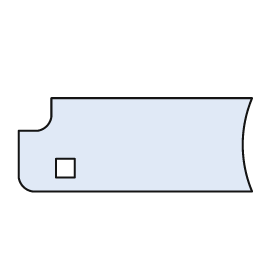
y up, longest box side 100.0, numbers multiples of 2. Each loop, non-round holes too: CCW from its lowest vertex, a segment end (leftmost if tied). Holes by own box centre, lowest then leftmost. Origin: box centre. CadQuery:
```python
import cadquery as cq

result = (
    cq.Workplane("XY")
    .moveTo(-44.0, -20.0)
    .lineTo(50.0, -20.0)
    .threePointArc((46.0, 0.0), (50.0, 20.0))
    .lineTo(-36.0, 20.0)
    .lineTo(-36.0, 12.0)
    .threePointArc((-38.0, 8.0), (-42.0, 6.0))
    .lineTo(-50.0, 6.0)
    .lineTo(-50.0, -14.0)
    .threePointArc((-48.0, -18.0), (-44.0, -20.0))
    .close()
    .moveTo(-34.0, -14.0)
    .lineTo(-26.0, -14.0)
    .lineTo(-26.0, -6.0)
    .lineTo(-34.0, -6.0)
    .close()
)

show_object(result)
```